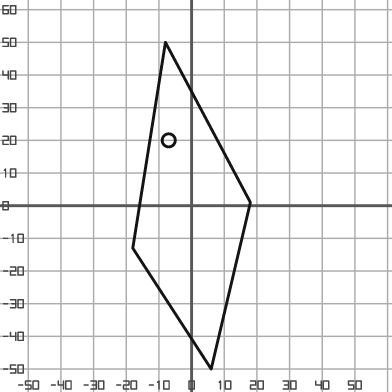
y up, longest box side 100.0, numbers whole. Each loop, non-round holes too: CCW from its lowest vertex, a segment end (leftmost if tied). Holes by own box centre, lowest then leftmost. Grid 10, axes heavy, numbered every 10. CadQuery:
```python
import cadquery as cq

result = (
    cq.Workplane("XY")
    .moveTo(6.0, -50.0)
    .lineTo(18.0, 1.0)
    .lineTo(-8.0, 50.0)
    .lineTo(-18.0, -13.0)
    .close()
    .moveTo(-7.0, 20.0)
    .circle(2.0)
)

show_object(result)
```